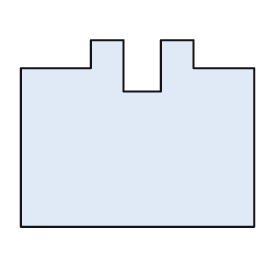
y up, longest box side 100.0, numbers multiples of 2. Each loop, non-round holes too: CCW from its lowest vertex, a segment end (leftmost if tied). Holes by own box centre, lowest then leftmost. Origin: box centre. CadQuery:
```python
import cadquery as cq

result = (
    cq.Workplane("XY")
    .moveTo(-50.0, -40.0)
    .lineTo(50.0, -40.0)
    .lineTo(50.0, 28.0)
    .lineTo(24.0, 28.0)
    .lineTo(24.0, 40.0)
    .lineTo(10.0, 40.0)
    .lineTo(10.0, 18.0)
    .lineTo(-6.0, 18.0)
    .lineTo(-6.0, 40.0)
    .lineTo(-20.0, 40.0)
    .lineTo(-20.0, 28.0)
    .lineTo(-50.0, 28.0)
    .close()
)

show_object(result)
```